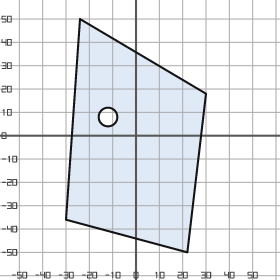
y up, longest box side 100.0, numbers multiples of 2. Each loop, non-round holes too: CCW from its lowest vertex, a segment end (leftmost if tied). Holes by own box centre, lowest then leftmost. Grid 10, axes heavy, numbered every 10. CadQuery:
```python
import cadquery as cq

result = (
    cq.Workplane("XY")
    .moveTo(22.0, -50.0)
    .lineTo(30.0, 18.0)
    .lineTo(-24.0, 50.0)
    .lineTo(-30.0, -36.0)
    .close()
    .moveTo(-12.0, 8.0)
    .circle(4.0)
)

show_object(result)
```